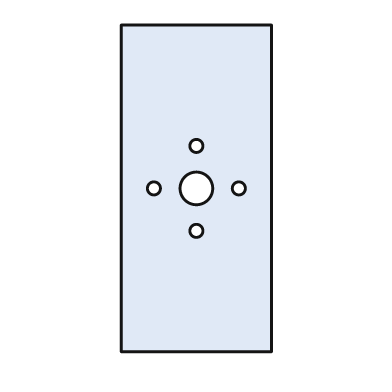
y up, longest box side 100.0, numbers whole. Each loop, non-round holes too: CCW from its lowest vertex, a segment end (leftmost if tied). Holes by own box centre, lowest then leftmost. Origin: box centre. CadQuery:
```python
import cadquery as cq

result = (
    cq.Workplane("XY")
    .moveTo(-23.0, -50.0)
    .lineTo(23.0, -50.0)
    .lineTo(23.0, 50.0)
    .lineTo(-23.0, 50.0)
    .close()
    .moveTo(0.0, -13.0)
    .circle(2.0)
    .moveTo(-13.0, 0.0)
    .circle(2.0)
    .moveTo(0.0, 0.0)
    .circle(5.0)
    .moveTo(13.0, 0.0)
    .circle(2.0)
    .moveTo(0.0, 13.0)
    .circle(2.0)
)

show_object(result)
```